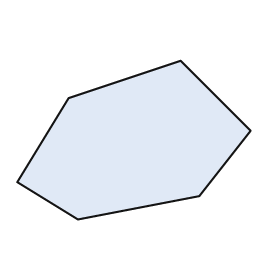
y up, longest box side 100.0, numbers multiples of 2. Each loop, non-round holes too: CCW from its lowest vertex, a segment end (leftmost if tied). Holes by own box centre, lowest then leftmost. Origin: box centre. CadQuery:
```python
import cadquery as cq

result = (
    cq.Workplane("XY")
    .moveTo(-24.0, -34.0)
    .lineTo(28.0, -24.0)
    .lineTo(50.0, 4.0)
    .lineTo(20.0, 34.0)
    .lineTo(-28.0, 18.0)
    .lineTo(-50.0, -18.0)
    .close()
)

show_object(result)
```